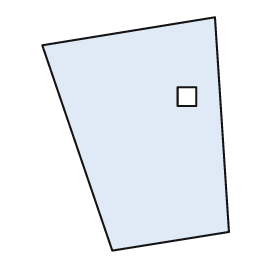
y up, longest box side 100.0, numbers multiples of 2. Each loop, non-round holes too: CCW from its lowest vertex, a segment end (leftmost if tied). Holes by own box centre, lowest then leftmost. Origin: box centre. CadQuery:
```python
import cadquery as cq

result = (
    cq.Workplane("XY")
    .moveTo(-10.0, -50.0)
    .lineTo(40.0, -42.0)
    .lineTo(34.0, 50.0)
    .lineTo(-40.0, 38.0)
    .close()
    .moveTo(18.0, 12.0)
    .lineTo(26.0, 12.0)
    .lineTo(26.0, 20.0)
    .lineTo(18.0, 20.0)
    .close()
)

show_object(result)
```